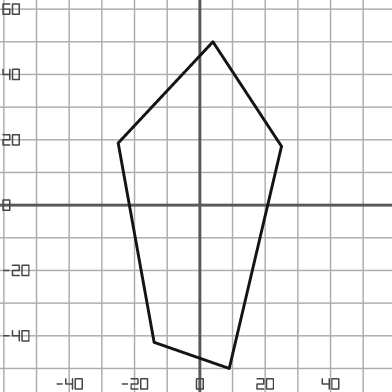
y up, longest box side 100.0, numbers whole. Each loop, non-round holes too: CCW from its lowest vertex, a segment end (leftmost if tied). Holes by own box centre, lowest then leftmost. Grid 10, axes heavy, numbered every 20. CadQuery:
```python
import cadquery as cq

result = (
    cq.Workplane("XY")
    .moveTo(9.0, -50.0)
    .lineTo(25.0, 18.0)
    .lineTo(4.0, 50.0)
    .lineTo(-25.0, 19.0)
    .lineTo(-14.0, -42.0)
    .close()
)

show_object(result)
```